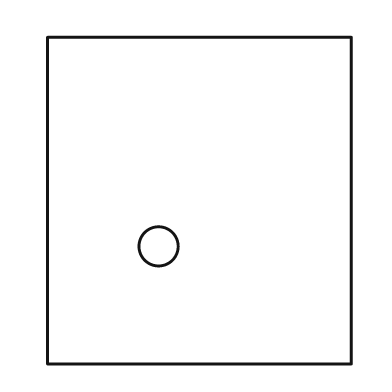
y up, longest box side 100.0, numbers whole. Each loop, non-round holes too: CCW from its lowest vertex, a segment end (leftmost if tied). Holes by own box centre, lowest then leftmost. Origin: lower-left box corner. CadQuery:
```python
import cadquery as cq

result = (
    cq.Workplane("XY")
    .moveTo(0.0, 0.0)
    .lineTo(93.0, 0.0)
    .lineTo(93.0, 100.0)
    .lineTo(0.0, 100.0)
    .close()
    .moveTo(34.0, 36.0)
    .circle(6.0)
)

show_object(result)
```